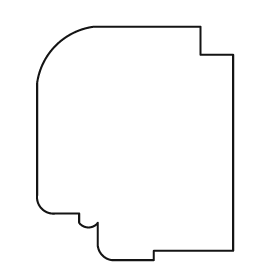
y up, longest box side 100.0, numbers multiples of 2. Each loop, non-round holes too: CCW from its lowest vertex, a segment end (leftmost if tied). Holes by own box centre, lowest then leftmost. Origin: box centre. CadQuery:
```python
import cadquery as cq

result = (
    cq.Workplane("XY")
    .moveTo(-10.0, -50.0)
    .lineTo(8.0, -50.0)
    .lineTo(8.0, -46.0)
    .lineTo(42.0, -46.0)
    .lineTo(42.0, 38.0)
    .lineTo(28.0, 38.0)
    .lineTo(28.0, 50.0)
    .lineTo(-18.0, 50.0)
    .threePointArc((-34.0, 42.0), (-42.0, 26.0))
    .lineTo(-42.0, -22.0)
    .threePointArc((-40.0, -28.0), (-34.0, -30.0))
    .lineTo(-24.0, -30.0)
    .lineTo(-24.0, -34.0)
    .threePointArc((-20.0, -36.0), (-16.0, -34.0))
    .lineTo(-16.0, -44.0)
    .threePointArc((-14.0, -48.0), (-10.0, -50.0))
    .close()
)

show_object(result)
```